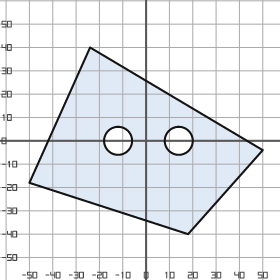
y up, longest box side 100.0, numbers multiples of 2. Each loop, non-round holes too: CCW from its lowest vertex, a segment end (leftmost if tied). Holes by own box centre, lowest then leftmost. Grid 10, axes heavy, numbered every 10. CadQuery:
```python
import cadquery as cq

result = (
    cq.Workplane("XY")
    .moveTo(18.0, -40.0)
    .lineTo(50.0, -4.0)
    .lineTo(-24.0, 40.0)
    .lineTo(-50.0, -18.0)
    .close()
    .moveTo(-12.0, 0.0)
    .circle(6.0)
    .moveTo(14.0, 0.0)
    .circle(6.0)
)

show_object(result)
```